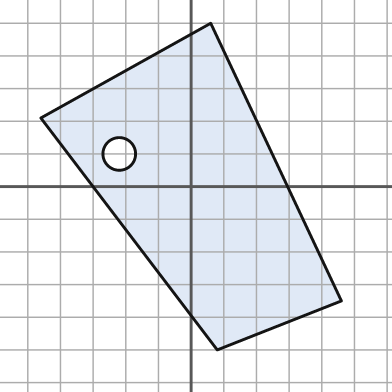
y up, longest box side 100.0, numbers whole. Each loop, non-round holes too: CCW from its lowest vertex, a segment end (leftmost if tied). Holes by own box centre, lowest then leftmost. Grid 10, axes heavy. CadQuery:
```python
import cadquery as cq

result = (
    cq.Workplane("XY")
    .moveTo(8.0, -50.0)
    .lineTo(46.0, -35.0)
    .lineTo(6.0, 50.0)
    .lineTo(-46.0, 21.0)
    .close()
    .moveTo(-22.0, 10.0)
    .circle(5.0)
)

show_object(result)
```